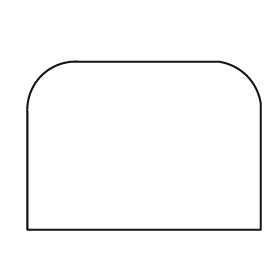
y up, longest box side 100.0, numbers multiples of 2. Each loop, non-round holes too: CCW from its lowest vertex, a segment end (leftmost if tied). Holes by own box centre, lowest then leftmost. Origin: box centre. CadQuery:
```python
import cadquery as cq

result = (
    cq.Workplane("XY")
    .moveTo(-50.0, -36.0)
    .lineTo(50.0, -36.0)
    .lineTo(50.0, 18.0)
    .threePointArc((44.0, 30.0), (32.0, 36.0))
    .lineTo(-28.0, 36.0)
    .threePointArc((-44.0, 30.0), (-50.0, 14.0))
    .close()
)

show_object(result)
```